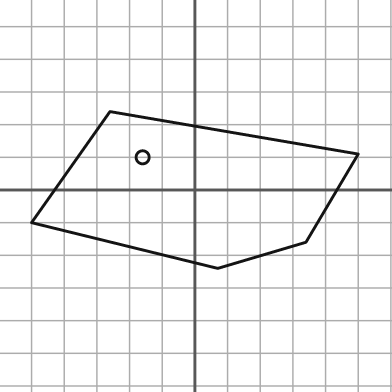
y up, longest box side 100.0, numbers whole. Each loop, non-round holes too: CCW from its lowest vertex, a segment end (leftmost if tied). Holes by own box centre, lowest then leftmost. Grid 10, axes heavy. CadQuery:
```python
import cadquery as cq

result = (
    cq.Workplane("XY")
    .moveTo(7.0, -24.0)
    .lineTo(34.0, -16.0)
    .lineTo(50.0, 11.0)
    .lineTo(-26.0, 24.0)
    .lineTo(-50.0, -10.0)
    .close()
    .moveTo(-16.0, 10.0)
    .circle(2.0)
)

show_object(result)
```